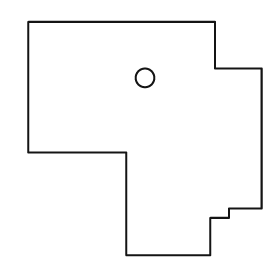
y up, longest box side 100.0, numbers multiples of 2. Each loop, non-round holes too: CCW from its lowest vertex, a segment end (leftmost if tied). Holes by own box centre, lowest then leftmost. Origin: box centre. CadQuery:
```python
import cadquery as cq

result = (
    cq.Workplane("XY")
    .moveTo(-8.0, -50.0)
    .lineTo(28.0, -50.0)
    .lineTo(28.0, -34.0)
    .lineTo(36.0, -34.0)
    .lineTo(36.0, -30.0)
    .lineTo(50.0, -30.0)
    .lineTo(50.0, 30.0)
    .lineTo(30.0, 30.0)
    .lineTo(30.0, 50.0)
    .lineTo(-50.0, 50.0)
    .lineTo(-50.0, -6.0)
    .lineTo(-8.0, -6.0)
    .close()
    .moveTo(0.0, 26.0)
    .circle(4.0)
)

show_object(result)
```